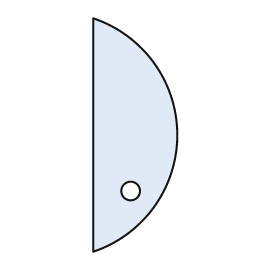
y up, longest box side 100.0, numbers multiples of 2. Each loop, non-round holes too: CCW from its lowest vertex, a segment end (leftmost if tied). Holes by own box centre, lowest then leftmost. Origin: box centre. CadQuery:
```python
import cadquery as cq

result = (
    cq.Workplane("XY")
    .moveTo(-18.0, -50.0)
    .threePointArc((18.0, 0.0), (-18.0, 50.0))
    .close()
    .moveTo(-2.0, -24.0)
    .circle(4.0)
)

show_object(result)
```